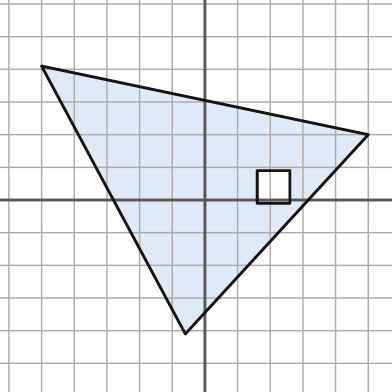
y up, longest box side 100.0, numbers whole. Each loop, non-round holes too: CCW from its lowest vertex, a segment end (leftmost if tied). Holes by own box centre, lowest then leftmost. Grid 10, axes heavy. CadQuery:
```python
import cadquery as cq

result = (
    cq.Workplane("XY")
    .moveTo(-6.0, -41.0)
    .lineTo(50.0, 20.0)
    .lineTo(-50.0, 41.0)
    .close()
    .moveTo(16.0, -1.0)
    .lineTo(26.0, -1.0)
    .lineTo(26.0, 9.0)
    .lineTo(16.0, 9.0)
    .close()
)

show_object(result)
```